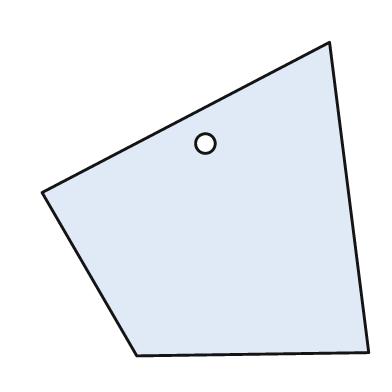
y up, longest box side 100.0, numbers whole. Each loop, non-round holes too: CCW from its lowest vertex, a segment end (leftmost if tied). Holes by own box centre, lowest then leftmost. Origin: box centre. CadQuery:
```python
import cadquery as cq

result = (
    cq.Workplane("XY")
    .moveTo(-21.0, -48.0)
    .lineTo(50.0, -47.0)
    .lineTo(38.0, 48.0)
    .lineTo(-50.0, 2.0)
    .close()
    .moveTo(0.0, 17.0)
    .circle(3.0)
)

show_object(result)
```